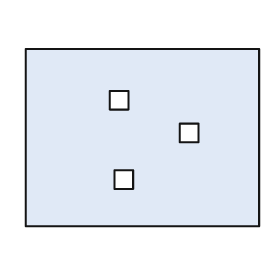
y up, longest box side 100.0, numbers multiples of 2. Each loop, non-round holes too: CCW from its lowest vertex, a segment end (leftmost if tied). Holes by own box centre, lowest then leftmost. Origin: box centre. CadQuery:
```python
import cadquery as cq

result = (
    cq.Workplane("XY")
    .moveTo(-50.0, -38.0)
    .lineTo(50.0, -38.0)
    .lineTo(50.0, 38.0)
    .lineTo(-50.0, 38.0)
    .close()
    .moveTo(-12.0, -22.0)
    .lineTo(-4.0, -22.0)
    .lineTo(-4.0, -14.0)
    .lineTo(-12.0, -14.0)
    .close()
    .moveTo(16.0, -2.0)
    .lineTo(24.0, -2.0)
    .lineTo(24.0, 6.0)
    .lineTo(16.0, 6.0)
    .close()
    .moveTo(-14.0, 12.0)
    .lineTo(-6.0, 12.0)
    .lineTo(-6.0, 20.0)
    .lineTo(-14.0, 20.0)
    .close()
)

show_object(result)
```